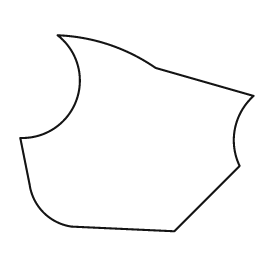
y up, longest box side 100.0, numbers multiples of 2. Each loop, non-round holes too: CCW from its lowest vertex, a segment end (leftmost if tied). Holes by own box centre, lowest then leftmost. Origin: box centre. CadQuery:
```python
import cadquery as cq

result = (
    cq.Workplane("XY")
    .moveTo(16.0, -42.0)
    .lineTo(44.0, -14.0)
    .threePointArc((42.0, 2.0), (50.0, 16.0))
    .lineTo(8.0, 28.0)
    .threePointArc((-12.0, 38.0), (-34.0, 42.0))
    .threePointArc((-26.0, 14.0), (-50.0, -2.0))
    .lineTo(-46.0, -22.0)
    .threePointArc((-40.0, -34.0), (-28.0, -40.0))
    .close()
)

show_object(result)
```